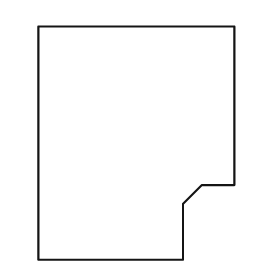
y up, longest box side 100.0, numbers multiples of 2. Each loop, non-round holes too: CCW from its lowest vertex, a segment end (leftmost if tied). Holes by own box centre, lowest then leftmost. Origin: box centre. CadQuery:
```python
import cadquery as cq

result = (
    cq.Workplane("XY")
    .moveTo(-42.0, -50.0)
    .lineTo(20.0, -50.0)
    .lineTo(20.0, -26.0)
    .lineTo(28.0, -18.0)
    .lineTo(42.0, -18.0)
    .lineTo(42.0, 50.0)
    .lineTo(-42.0, 50.0)
    .close()
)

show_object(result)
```